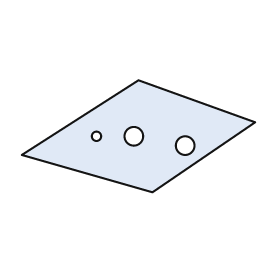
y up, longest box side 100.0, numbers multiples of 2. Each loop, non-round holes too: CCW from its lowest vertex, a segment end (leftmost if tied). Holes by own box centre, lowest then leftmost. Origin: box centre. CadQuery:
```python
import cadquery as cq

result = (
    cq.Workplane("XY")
    .moveTo(6.0, -24.0)
    .lineTo(50.0, 6.0)
    .lineTo(0.0, 24.0)
    .lineTo(-50.0, -8.0)
    .close()
    .moveTo(20.0, -4.0)
    .circle(4.0)
    .moveTo(-18.0, 0.0)
    .circle(2.0)
    .moveTo(-2.0, 0.0)
    .circle(4.0)
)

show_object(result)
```